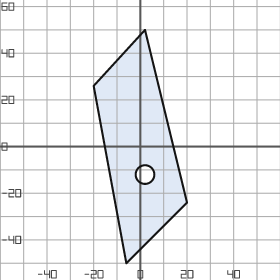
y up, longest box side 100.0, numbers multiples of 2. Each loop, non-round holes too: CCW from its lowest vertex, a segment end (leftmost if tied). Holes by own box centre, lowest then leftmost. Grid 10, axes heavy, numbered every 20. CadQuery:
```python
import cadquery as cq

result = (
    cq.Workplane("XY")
    .moveTo(-6.0, -50.0)
    .lineTo(20.0, -24.0)
    .lineTo(2.0, 50.0)
    .lineTo(-20.0, 26.0)
    .close()
    .moveTo(2.0, -12.0)
    .circle(4.0)
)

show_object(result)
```